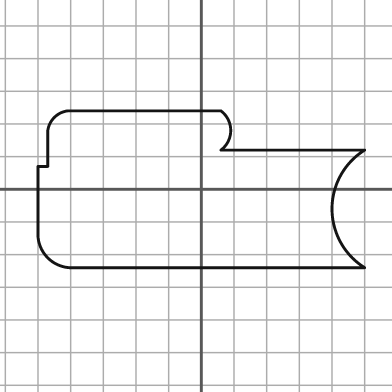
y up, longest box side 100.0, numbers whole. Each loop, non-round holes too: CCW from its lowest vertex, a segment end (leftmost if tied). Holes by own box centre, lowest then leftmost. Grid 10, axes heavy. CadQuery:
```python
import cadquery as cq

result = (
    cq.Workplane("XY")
    .moveTo(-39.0, -24.0)
    .lineTo(50.0, -24.0)
    .threePointArc((40.0, -6.0), (50.0, 12.0))
    .lineTo(6.0, 12.0)
    .threePointArc((9.0, 18.0), (6.0, 24.0))
    .lineTo(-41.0, 24.0)
    .threePointArc((-45.0, 22.0), (-47.0, 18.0))
    .lineTo(-47.0, 7.0)
    .lineTo(-50.0, 7.0)
    .lineTo(-50.0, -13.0)
    .threePointArc((-47.0, -21.0), (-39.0, -24.0))
    .close()
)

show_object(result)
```